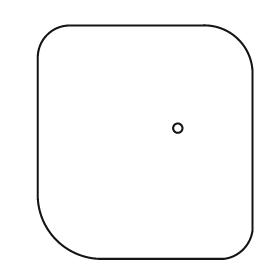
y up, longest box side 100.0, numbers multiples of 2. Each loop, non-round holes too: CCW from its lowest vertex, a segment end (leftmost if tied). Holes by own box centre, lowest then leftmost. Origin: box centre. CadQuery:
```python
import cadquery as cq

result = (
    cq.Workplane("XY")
    .moveTo(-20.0, -50.0)
    .lineTo(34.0, -50.0)
    .threePointArc((42.0, -46.0), (46.0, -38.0))
    .lineTo(46.0, 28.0)
    .threePointArc((40.0, 44.0), (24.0, 50.0))
    .lineTo(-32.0, 50.0)
    .threePointArc((-42.0, 46.0), (-46.0, 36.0))
    .lineTo(-46.0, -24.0)
    .threePointArc((-38.0, -42.0), (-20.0, -50.0))
    .close()
    .moveTo(14.0, 6.0)
    .circle(2.0)
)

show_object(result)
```